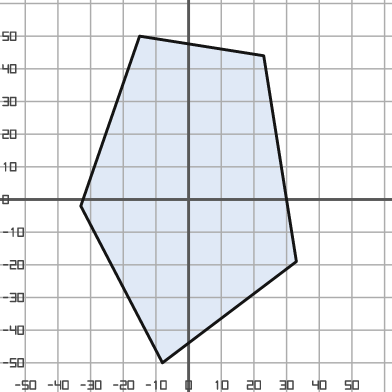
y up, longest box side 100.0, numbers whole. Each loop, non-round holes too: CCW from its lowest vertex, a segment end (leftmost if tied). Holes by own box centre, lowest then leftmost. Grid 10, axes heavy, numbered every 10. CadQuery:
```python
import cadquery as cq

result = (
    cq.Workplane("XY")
    .moveTo(-8.0, -50.0)
    .lineTo(33.0, -19.0)
    .lineTo(23.0, 44.0)
    .lineTo(-15.0, 50.0)
    .lineTo(-33.0, -2.0)
    .close()
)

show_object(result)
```